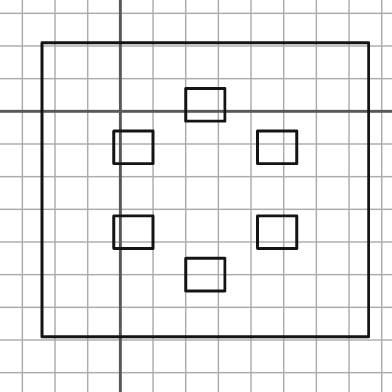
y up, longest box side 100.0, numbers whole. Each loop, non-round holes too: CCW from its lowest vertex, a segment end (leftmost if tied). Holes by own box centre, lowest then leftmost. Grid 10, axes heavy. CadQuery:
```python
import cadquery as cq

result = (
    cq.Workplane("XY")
    .moveTo(-24.0, -69.0)
    .lineTo(76.0, -69.0)
    .lineTo(76.0, 21.0)
    .lineTo(-24.0, 21.0)
    .close()
    .moveTo(20.0, -55.0)
    .lineTo(32.0, -55.0)
    .lineTo(32.0, -45.0)
    .lineTo(20.0, -45.0)
    .close()
    .moveTo(-2.0, -42.0)
    .lineTo(10.0, -42.0)
    .lineTo(10.0, -32.0)
    .lineTo(-2.0, -32.0)
    .close()
    .moveTo(42.0, -42.0)
    .lineTo(54.0, -42.0)
    .lineTo(54.0, -32.0)
    .lineTo(42.0, -32.0)
    .close()
    .moveTo(-2.0, -16.0)
    .lineTo(10.0, -16.0)
    .lineTo(10.0, -6.0)
    .lineTo(-2.0, -6.0)
    .close()
    .moveTo(42.0, -16.0)
    .lineTo(54.0, -16.0)
    .lineTo(54.0, -6.0)
    .lineTo(42.0, -6.0)
    .close()
    .moveTo(20.0, -3.0)
    .lineTo(32.0, -3.0)
    .lineTo(32.0, 7.0)
    .lineTo(20.0, 7.0)
    .close()
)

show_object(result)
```